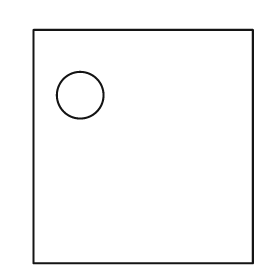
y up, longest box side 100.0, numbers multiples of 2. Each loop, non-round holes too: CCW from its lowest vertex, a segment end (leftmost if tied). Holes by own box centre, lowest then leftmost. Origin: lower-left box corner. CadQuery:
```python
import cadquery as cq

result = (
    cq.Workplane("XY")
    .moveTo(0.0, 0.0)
    .lineTo(94.0, 0.0)
    .lineTo(94.0, 100.0)
    .lineTo(0.0, 100.0)
    .close()
    .moveTo(20.0, 72.0)
    .circle(10.0)
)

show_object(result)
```